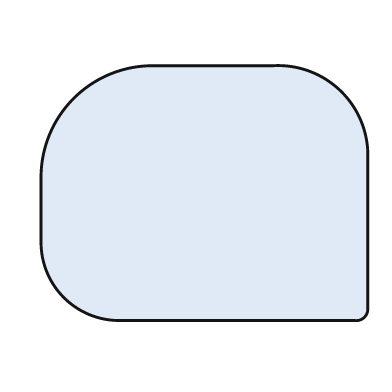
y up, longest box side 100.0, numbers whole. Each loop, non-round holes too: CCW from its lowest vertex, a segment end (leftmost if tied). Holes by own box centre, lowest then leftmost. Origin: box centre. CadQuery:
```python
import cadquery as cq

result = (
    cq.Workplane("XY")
    .moveTo(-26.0, -39.0)
    .lineTo(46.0, -39.0)
    .threePointArc((49.0, -38.0), (50.0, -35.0))
    .lineTo(50.0, 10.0)
    .threePointArc((42.0, 31.0), (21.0, 39.0))
    .lineTo(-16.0, 39.0)
    .threePointArc((-40.0, 29.0), (-50.0, 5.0))
    .lineTo(-50.0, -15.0)
    .threePointArc((-43.0, -32.0), (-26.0, -39.0))
    .close()
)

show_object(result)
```